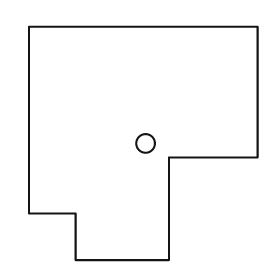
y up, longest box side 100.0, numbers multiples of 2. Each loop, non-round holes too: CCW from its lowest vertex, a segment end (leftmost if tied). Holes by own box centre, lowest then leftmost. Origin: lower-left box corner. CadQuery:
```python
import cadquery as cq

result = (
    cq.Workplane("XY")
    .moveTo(20.0, 0.0)
    .lineTo(60.0, 0.0)
    .lineTo(60.0, 44.0)
    .lineTo(98.0, 44.0)
    .lineTo(98.0, 100.0)
    .lineTo(0.0, 100.0)
    .lineTo(0.0, 20.0)
    .lineTo(20.0, 20.0)
    .close()
    .moveTo(50.0, 50.0)
    .circle(4.0)
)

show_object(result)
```